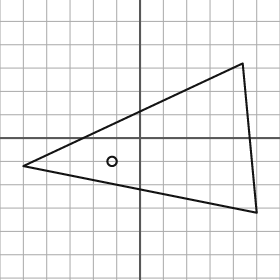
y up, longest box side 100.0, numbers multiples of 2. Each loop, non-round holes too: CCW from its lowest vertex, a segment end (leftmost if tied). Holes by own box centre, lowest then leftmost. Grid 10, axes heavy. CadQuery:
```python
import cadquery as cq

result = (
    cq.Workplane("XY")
    .moveTo(50.0, -32.0)
    .lineTo(44.0, 32.0)
    .lineTo(-50.0, -12.0)
    .close()
    .moveTo(-12.0, -10.0)
    .circle(2.0)
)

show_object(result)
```